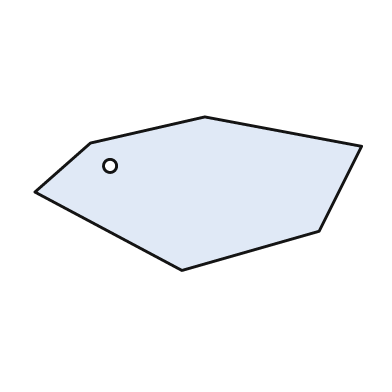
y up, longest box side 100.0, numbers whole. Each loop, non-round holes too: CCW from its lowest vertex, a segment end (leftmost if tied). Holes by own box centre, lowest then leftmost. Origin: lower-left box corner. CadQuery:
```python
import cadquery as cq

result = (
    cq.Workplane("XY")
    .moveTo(45.0, 0.0)
    .lineTo(87.0, 12.0)
    .lineTo(100.0, 38.0)
    .lineTo(52.0, 47.0)
    .lineTo(17.0, 39.0)
    .lineTo(0.0, 24.0)
    .close()
    .moveTo(23.0, 32.0)
    .circle(2.0)
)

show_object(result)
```